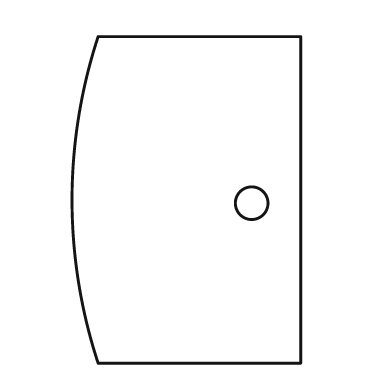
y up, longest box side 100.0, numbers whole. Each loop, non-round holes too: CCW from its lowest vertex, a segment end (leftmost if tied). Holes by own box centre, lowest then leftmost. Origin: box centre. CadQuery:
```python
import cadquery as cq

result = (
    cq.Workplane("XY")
    .moveTo(-27.0, -50.0)
    .lineTo(35.0, -50.0)
    .lineTo(35.0, 50.0)
    .lineTo(-27.0, 50.0)
    .threePointArc((-35.0, 0.0), (-27.0, -50.0))
    .close()
    .moveTo(20.0, -1.0)
    .circle(5.0)
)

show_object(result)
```